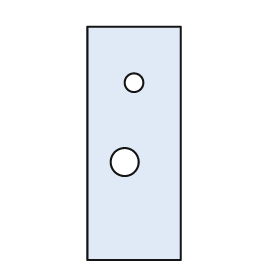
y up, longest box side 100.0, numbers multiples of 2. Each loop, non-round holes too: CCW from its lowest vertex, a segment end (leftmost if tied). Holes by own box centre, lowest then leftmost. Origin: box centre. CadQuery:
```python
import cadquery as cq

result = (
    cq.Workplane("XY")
    .moveTo(-20.0, -50.0)
    .lineTo(20.0, -50.0)
    .lineTo(20.0, 50.0)
    .lineTo(-20.0, 50.0)
    .close()
    .moveTo(-4.0, -8.0)
    .circle(6.0)
    .moveTo(0.0, 26.0)
    .circle(4.0)
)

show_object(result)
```